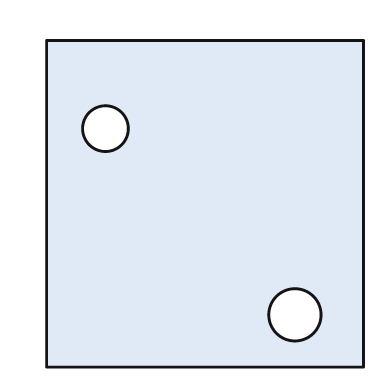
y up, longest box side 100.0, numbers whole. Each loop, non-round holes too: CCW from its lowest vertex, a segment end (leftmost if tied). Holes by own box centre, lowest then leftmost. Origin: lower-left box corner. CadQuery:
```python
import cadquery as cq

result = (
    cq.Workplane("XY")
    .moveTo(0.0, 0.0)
    .lineTo(97.0, 0.0)
    .lineTo(97.0, 100.0)
    .lineTo(0.0, 100.0)
    .close()
    .moveTo(76.0, 16.0)
    .circle(8.0)
    .moveTo(18.0, 73.0)
    .circle(7.0)
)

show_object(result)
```